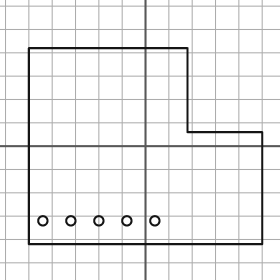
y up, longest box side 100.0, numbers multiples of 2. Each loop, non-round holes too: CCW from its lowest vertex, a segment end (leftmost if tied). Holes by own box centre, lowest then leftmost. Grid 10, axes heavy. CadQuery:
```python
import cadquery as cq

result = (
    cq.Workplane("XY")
    .moveTo(-50.0, -42.0)
    .lineTo(50.0, -42.0)
    .lineTo(50.0, 6.0)
    .lineTo(18.0, 6.0)
    .lineTo(18.0, 42.0)
    .lineTo(-50.0, 42.0)
    .close()
    .moveTo(-44.0, -32.0)
    .circle(2.0)
    .moveTo(-32.0, -32.0)
    .circle(2.0)
    .moveTo(-20.0, -32.0)
    .circle(2.0)
    .moveTo(-8.0, -32.0)
    .circle(2.0)
    .moveTo(4.0, -32.0)
    .circle(2.0)
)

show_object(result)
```